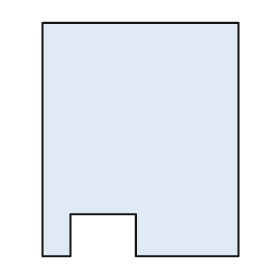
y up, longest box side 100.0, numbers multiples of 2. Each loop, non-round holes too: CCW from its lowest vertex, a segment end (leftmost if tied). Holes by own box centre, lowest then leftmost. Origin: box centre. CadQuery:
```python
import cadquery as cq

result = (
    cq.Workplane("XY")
    .moveTo(-42.0, -50.0)
    .lineTo(-30.0, -50.0)
    .lineTo(-30.0, -32.0)
    .lineTo(-2.0, -32.0)
    .lineTo(-2.0, -50.0)
    .lineTo(42.0, -50.0)
    .lineTo(42.0, 50.0)
    .lineTo(-42.0, 50.0)
    .close()
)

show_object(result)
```